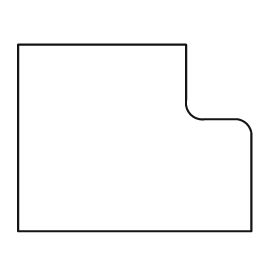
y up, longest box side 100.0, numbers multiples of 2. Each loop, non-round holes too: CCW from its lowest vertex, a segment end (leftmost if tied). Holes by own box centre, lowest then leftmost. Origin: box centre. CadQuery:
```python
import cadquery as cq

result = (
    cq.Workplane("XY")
    .moveTo(-50.0, -40.0)
    .lineTo(50.0, -40.0)
    .lineTo(50.0, 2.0)
    .threePointArc((48.0, 6.0), (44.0, 8.0))
    .lineTo(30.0, 8.0)
    .threePointArc((24.0, 10.0), (22.0, 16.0))
    .lineTo(22.0, 40.0)
    .lineTo(-50.0, 40.0)
    .close()
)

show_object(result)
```